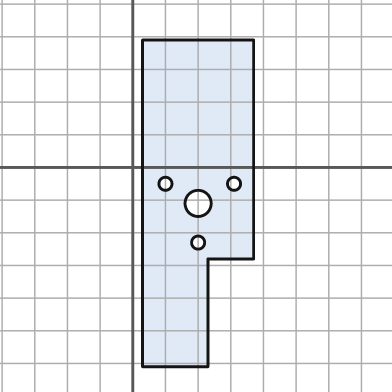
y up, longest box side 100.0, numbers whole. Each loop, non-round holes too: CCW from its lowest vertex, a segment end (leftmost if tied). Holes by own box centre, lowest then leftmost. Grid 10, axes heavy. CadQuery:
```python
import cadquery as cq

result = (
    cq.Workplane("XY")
    .moveTo(3.0, -61.0)
    .lineTo(23.0, -61.0)
    .lineTo(23.0, -28.0)
    .lineTo(37.0, -28.0)
    .lineTo(37.0, 39.0)
    .lineTo(3.0, 39.0)
    .close()
    .moveTo(20.0, -23.0)
    .circle(2.0)
    .moveTo(20.0, -11.0)
    .circle(4.0)
    .moveTo(10.0, -5.0)
    .circle(2.0)
    .moveTo(31.0, -5.0)
    .circle(2.0)
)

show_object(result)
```